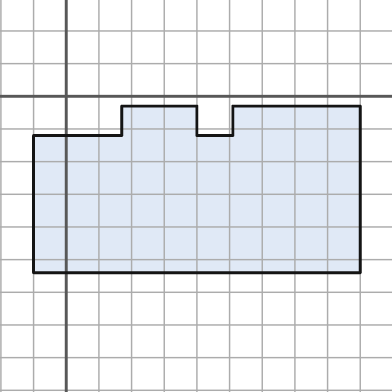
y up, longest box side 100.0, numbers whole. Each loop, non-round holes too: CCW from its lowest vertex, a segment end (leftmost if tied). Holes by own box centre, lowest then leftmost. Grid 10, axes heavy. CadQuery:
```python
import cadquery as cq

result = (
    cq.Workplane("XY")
    .moveTo(-10.0, -54.0)
    .lineTo(90.0, -54.0)
    .lineTo(90.0, -3.0)
    .lineTo(51.0, -3.0)
    .lineTo(51.0, -12.0)
    .lineTo(40.0, -12.0)
    .lineTo(40.0, -3.0)
    .lineTo(17.0, -3.0)
    .lineTo(17.0, -12.0)
    .lineTo(-10.0, -12.0)
    .close()
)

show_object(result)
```